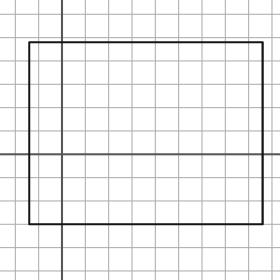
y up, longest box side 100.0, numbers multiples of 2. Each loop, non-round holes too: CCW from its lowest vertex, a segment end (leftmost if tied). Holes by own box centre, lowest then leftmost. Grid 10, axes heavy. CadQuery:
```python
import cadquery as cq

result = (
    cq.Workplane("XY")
    .moveTo(-14.0, -30.0)
    .lineTo(86.0, -30.0)
    .lineTo(86.0, 48.0)
    .lineTo(-14.0, 48.0)
    .close()
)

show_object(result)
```